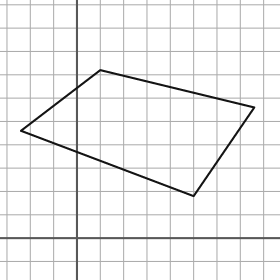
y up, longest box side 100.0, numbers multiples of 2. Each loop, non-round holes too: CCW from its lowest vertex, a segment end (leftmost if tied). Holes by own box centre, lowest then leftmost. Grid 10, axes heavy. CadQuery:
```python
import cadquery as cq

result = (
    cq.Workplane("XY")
    .moveTo(50.0, 18.0)
    .lineTo(76.0, 56.0)
    .lineTo(10.0, 72.0)
    .lineTo(-24.0, 46.0)
    .close()
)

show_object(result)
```